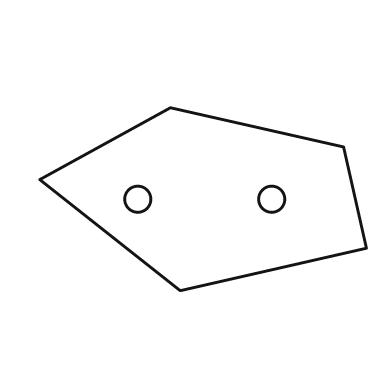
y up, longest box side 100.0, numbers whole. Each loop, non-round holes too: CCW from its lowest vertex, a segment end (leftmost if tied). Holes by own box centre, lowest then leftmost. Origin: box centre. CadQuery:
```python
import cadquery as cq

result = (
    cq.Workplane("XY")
    .moveTo(-7.0, -28.0)
    .lineTo(50.0, -15.0)
    .lineTo(43.0, 16.0)
    .lineTo(-10.0, 28.0)
    .lineTo(-50.0, 6.0)
    .close()
    .moveTo(-20.0, 0.0)
    .circle(4.0)
    .moveTo(21.0, 0.0)
    .circle(4.0)
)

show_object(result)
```